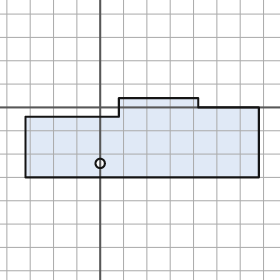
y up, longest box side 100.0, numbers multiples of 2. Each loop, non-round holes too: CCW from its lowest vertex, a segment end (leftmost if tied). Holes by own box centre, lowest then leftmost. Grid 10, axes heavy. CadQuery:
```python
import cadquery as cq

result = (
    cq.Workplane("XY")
    .moveTo(-32.0, -30.0)
    .lineTo(68.0, -30.0)
    .lineTo(68.0, 0.0)
    .lineTo(42.0, 0.0)
    .lineTo(42.0, 4.0)
    .lineTo(8.0, 4.0)
    .lineTo(8.0, -4.0)
    .lineTo(-32.0, -4.0)
    .close()
    .moveTo(0.0, -24.0)
    .circle(2.0)
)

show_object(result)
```